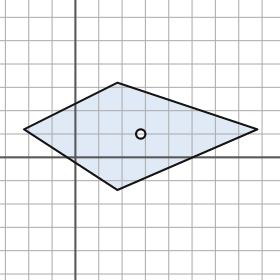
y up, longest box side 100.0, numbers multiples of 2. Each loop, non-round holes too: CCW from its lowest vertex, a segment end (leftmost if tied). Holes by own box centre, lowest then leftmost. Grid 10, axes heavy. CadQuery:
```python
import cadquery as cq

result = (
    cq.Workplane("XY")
    .moveTo(18.0, -14.0)
    .lineTo(78.0, 12.0)
    .lineTo(18.0, 32.0)
    .lineTo(-22.0, 12.0)
    .close()
    .moveTo(28.0, 10.0)
    .circle(2.0)
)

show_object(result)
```